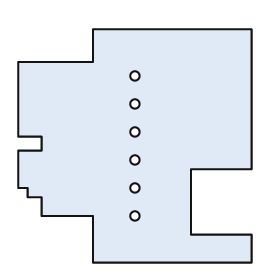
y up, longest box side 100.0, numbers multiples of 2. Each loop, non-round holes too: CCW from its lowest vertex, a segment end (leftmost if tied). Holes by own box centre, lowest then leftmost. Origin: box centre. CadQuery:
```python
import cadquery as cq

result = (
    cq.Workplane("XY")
    .moveTo(-18.0, -50.0)
    .lineTo(50.0, -50.0)
    .lineTo(50.0, -38.0)
    .lineTo(24.0, -38.0)
    .lineTo(24.0, -10.0)
    .lineTo(50.0, -10.0)
    .lineTo(50.0, 50.0)
    .lineTo(-18.0, 50.0)
    .lineTo(-18.0, 36.0)
    .lineTo(-50.0, 36.0)
    .lineTo(-50.0, 4.0)
    .lineTo(-40.0, 4.0)
    .lineTo(-40.0, -2.0)
    .lineTo(-50.0, -2.0)
    .lineTo(-50.0, -18.0)
    .lineTo(-46.0, -18.0)
    .lineTo(-46.0, -22.0)
    .lineTo(-40.0, -22.0)
    .lineTo(-40.0, -30.0)
    .lineTo(-18.0, -30.0)
    .close()
    .moveTo(0.0, -30.0)
    .circle(2.0)
    .moveTo(0.0, -18.0)
    .circle(2.0)
    .moveTo(0.0, -6.0)
    .circle(2.0)
    .moveTo(0.0, 6.0)
    .circle(2.0)
    .moveTo(0.0, 18.0)
    .circle(2.0)
    .moveTo(0.0, 30.0)
    .circle(2.0)
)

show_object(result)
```